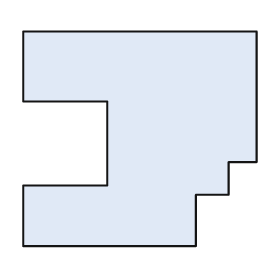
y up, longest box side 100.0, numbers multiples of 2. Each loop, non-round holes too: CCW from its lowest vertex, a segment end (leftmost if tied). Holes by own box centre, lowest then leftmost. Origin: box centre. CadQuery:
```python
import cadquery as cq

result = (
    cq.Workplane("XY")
    .moveTo(-50.0, -46.0)
    .lineTo(24.0, -46.0)
    .lineTo(24.0, -24.0)
    .lineTo(38.0, -24.0)
    .lineTo(38.0, -10.0)
    .lineTo(50.0, -10.0)
    .lineTo(50.0, 46.0)
    .lineTo(-50.0, 46.0)
    .lineTo(-50.0, 16.0)
    .lineTo(-14.0, 16.0)
    .lineTo(-14.0, -20.0)
    .lineTo(-50.0, -20.0)
    .close()
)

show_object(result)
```